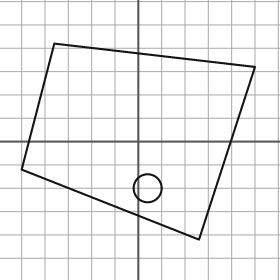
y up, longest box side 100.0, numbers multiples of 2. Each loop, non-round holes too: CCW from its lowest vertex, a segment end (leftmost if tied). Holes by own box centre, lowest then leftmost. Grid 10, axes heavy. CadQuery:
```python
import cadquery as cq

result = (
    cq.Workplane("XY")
    .moveTo(26.0, -42.0)
    .lineTo(50.0, 32.0)
    .lineTo(-36.0, 42.0)
    .lineTo(-50.0, -12.0)
    .close()
    .moveTo(4.0, -20.0)
    .circle(6.0)
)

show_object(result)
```